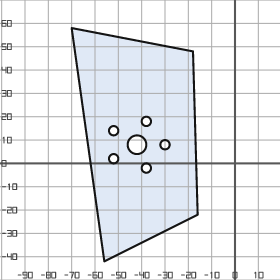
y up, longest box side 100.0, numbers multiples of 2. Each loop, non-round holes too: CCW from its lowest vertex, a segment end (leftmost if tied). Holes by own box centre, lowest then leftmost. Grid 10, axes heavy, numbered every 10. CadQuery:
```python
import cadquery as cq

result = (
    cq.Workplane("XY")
    .moveTo(-56.0, -42.0)
    .lineTo(-16.0, -22.0)
    .lineTo(-18.0, 48.0)
    .lineTo(-70.0, 58.0)
    .close()
    .moveTo(-38.0, -2.0)
    .circle(2.0)
    .moveTo(-52.0, 2.0)
    .circle(2.0)
    .moveTo(-42.0, 8.0)
    .circle(4.0)
    .moveTo(-30.0, 8.0)
    .circle(2.0)
    .moveTo(-52.0, 14.0)
    .circle(2.0)
    .moveTo(-38.0, 18.0)
    .circle(2.0)
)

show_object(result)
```